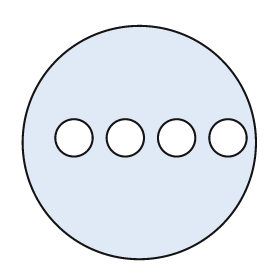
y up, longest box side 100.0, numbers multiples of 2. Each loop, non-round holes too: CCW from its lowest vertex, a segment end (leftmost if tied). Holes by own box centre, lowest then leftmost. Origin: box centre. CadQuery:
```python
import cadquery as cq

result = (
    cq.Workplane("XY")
    .moveTo(0.0, 0.0)
    .circle(50.0)
    .moveTo(-28.0, 2.0)
    .circle(8.0)
    .moveTo(-6.0, 2.0)
    .circle(8.0)
    .moveTo(16.0, 2.0)
    .circle(8.0)
    .moveTo(38.0, 2.0)
    .circle(8.0)
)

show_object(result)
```